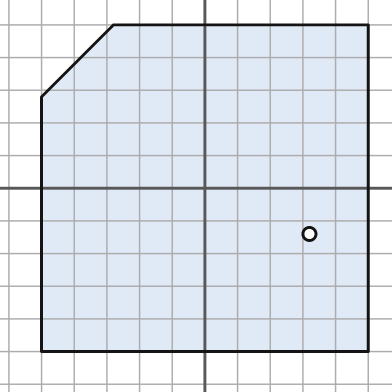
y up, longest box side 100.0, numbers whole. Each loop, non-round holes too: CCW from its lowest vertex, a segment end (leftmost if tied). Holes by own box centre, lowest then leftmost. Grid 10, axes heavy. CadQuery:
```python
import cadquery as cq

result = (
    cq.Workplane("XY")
    .moveTo(-50.0, -50.0)
    .lineTo(50.0, -50.0)
    .lineTo(50.0, 50.0)
    .lineTo(-28.0, 50.0)
    .lineTo(-50.0, 28.0)
    .close()
    .moveTo(32.0, -14.0)
    .circle(2.0)
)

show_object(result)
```